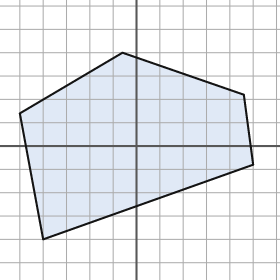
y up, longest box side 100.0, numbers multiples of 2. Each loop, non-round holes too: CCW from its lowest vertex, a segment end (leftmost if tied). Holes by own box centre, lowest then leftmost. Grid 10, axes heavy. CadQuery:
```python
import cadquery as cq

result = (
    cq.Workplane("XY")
    .moveTo(-40.0, -40.0)
    .lineTo(50.0, -8.0)
    .lineTo(46.0, 22.0)
    .lineTo(-6.0, 40.0)
    .lineTo(-50.0, 14.0)
    .close()
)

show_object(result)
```